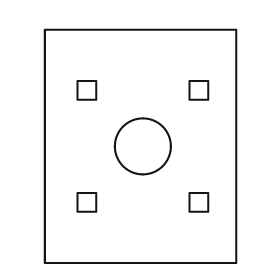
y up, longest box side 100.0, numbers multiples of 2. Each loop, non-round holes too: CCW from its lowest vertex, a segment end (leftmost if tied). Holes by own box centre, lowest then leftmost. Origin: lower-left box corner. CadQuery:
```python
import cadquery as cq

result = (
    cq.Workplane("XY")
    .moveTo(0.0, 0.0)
    .lineTo(82.0, 0.0)
    .lineTo(82.0, 100.0)
    .lineTo(0.0, 100.0)
    .close()
    .moveTo(14.0, 22.0)
    .lineTo(22.0, 22.0)
    .lineTo(22.0, 30.0)
    .lineTo(14.0, 30.0)
    .close()
    .moveTo(62.0, 22.0)
    .lineTo(70.0, 22.0)
    .lineTo(70.0, 30.0)
    .lineTo(62.0, 30.0)
    .close()
    .moveTo(42.0, 50.0)
    .circle(12.0)
    .moveTo(14.0, 70.0)
    .lineTo(22.0, 70.0)
    .lineTo(22.0, 78.0)
    .lineTo(14.0, 78.0)
    .close()
    .moveTo(62.0, 70.0)
    .lineTo(70.0, 70.0)
    .lineTo(70.0, 78.0)
    .lineTo(62.0, 78.0)
    .close()
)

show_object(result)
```